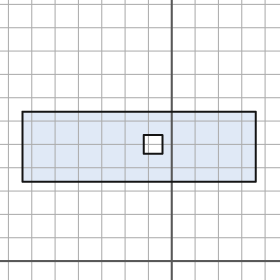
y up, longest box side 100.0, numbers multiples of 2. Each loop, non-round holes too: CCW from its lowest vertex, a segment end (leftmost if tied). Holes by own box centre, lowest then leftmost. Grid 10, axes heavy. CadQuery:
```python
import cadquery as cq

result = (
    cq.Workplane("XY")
    .moveTo(-64.0, 34.0)
    .lineTo(36.0, 34.0)
    .lineTo(36.0, 64.0)
    .lineTo(-64.0, 64.0)
    .close()
    .moveTo(-12.0, 46.0)
    .lineTo(-4.0, 46.0)
    .lineTo(-4.0, 54.0)
    .lineTo(-12.0, 54.0)
    .close()
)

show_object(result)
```